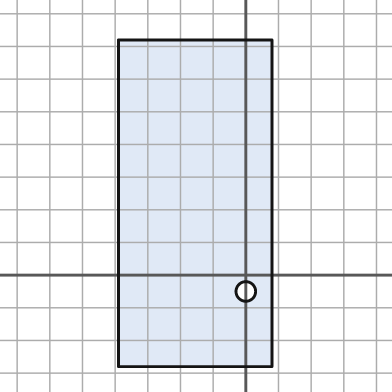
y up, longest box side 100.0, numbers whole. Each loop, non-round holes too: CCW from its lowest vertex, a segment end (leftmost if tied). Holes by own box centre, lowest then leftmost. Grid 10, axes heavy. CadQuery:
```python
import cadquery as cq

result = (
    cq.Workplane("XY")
    .moveTo(-39.0, -28.0)
    .lineTo(8.0, -28.0)
    .lineTo(8.0, 72.0)
    .lineTo(-39.0, 72.0)
    .close()
    .moveTo(0.0, -5.0)
    .circle(3.0)
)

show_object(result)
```